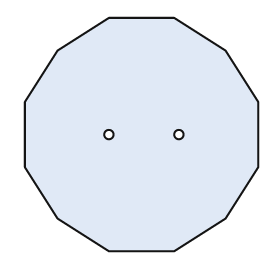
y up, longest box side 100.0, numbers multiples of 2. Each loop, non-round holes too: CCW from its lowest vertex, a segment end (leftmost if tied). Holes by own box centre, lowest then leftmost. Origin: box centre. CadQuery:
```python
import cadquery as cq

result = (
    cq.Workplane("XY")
    .moveTo(-14.0, -50.0)
    .lineTo(14.0, -50.0)
    .lineTo(36.0, -36.0)
    .lineTo(50.0, -14.0)
    .lineTo(50.0, 14.0)
    .lineTo(36.0, 36.0)
    .lineTo(14.0, 50.0)
    .lineTo(-14.0, 50.0)
    .lineTo(-36.0, 36.0)
    .lineTo(-50.0, 14.0)
    .lineTo(-50.0, -14.0)
    .lineTo(-36.0, -36.0)
    .close()
    .moveTo(-14.0, 0.0)
    .circle(2.0)
    .moveTo(16.0, 0.0)
    .circle(2.0)
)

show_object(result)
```